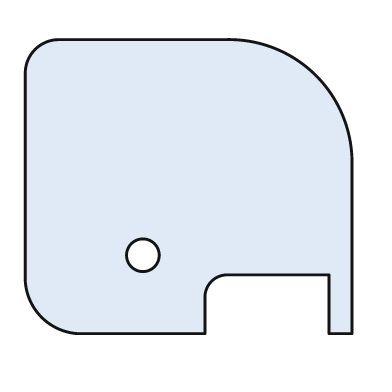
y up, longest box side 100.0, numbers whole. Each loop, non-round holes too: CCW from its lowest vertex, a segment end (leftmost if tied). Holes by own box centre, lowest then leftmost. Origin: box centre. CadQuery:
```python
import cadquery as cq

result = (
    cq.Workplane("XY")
    .moveTo(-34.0, -45.0)
    .lineTo(5.0, -45.0)
    .lineTo(5.0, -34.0)
    .threePointArc((7.0, -29.0), (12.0, -27.0))
    .lineTo(43.0, -27.0)
    .lineTo(43.0, -45.0)
    .lineTo(50.0, -45.0)
    .lineTo(50.0, 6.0)
    .threePointArc((39.0, 34.0), (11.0, 45.0))
    .lineTo(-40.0, 45.0)
    .threePointArc((-47.0, 42.0), (-50.0, 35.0))
    .lineTo(-50.0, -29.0)
    .threePointArc((-45.0, -40.0), (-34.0, -45.0))
    .close()
    .moveTo(-14.0, -21.0)
    .circle(5.0)
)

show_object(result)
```